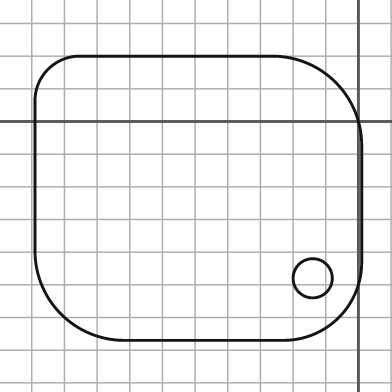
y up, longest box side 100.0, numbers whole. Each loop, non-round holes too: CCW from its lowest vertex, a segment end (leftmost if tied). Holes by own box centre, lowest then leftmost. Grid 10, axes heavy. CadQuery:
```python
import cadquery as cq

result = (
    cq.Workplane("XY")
    .moveTo(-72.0, -67.0)
    .lineTo(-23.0, -67.0)
    .threePointArc((-6.0, -60.0), (1.0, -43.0))
    .lineTo(1.0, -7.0)
    .threePointArc((-7.0, 12.0), (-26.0, 20.0))
    .lineTo(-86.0, 20.0)
    .threePointArc((-95.0, 16.0), (-99.0, 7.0))
    .lineTo(-99.0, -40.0)
    .threePointArc((-91.0, -59.0), (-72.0, -67.0))
    .close()
    .moveTo(-14.0, -48.0)
    .circle(6.0)
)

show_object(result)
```